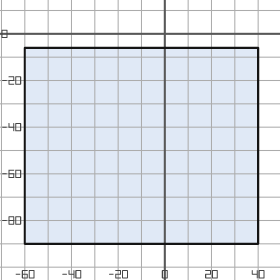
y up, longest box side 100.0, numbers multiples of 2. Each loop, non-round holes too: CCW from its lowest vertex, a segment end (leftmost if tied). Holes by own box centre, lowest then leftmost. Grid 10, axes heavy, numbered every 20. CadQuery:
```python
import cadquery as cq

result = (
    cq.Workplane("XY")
    .moveTo(-60.0, -90.0)
    .lineTo(40.0, -90.0)
    .lineTo(40.0, -6.0)
    .lineTo(-60.0, -6.0)
    .close()
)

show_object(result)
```